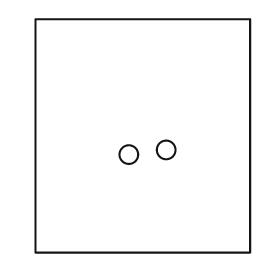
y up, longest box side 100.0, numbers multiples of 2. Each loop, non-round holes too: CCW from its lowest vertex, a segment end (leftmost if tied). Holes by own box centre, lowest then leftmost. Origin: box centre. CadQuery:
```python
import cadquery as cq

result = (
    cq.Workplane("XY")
    .moveTo(-46.0, -50.0)
    .lineTo(46.0, -50.0)
    .lineTo(46.0, 50.0)
    .lineTo(-46.0, 50.0)
    .close()
    .moveTo(-6.0, -8.0)
    .circle(4.0)
    .moveTo(10.0, -6.0)
    .circle(4.0)
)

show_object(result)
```